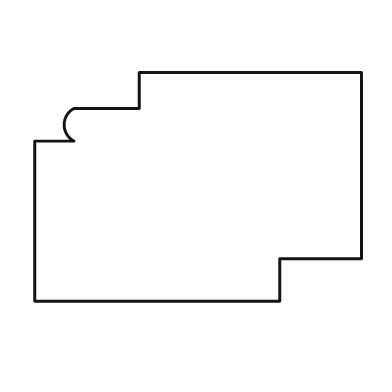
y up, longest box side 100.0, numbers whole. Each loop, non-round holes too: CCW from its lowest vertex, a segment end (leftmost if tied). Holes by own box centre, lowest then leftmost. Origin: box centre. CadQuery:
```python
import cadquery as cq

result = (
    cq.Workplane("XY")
    .moveTo(-50.0, -35.0)
    .lineTo(25.0, -35.0)
    .lineTo(25.0, -22.0)
    .lineTo(50.0, -22.0)
    .lineTo(50.0, 35.0)
    .lineTo(-18.0, 35.0)
    .lineTo(-18.0, 24.0)
    .lineTo(-38.0, 24.0)
    .threePointArc((-41.0, 19.0), (-38.0, 14.0))
    .lineTo(-50.0, 14.0)
    .close()
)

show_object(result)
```